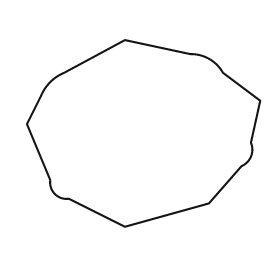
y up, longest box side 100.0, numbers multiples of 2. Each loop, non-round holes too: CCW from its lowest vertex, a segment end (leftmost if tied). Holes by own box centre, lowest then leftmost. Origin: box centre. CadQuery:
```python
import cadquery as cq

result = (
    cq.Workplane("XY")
    .moveTo(-8.0, -40.0)
    .lineTo(28.0, -30.0)
    .lineTo(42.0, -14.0)
    .threePointArc((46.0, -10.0), (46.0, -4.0))
    .lineTo(50.0, 14.0)
    .lineTo(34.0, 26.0)
    .threePointArc((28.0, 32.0), (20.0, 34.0))
    .lineTo(-8.0, 40.0)
    .lineTo(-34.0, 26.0)
    .threePointArc((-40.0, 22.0), (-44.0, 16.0))
    .lineTo(-50.0, 4.0)
    .lineTo(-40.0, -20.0)
    .threePointArc((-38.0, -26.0), (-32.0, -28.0))
    .close()
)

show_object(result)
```